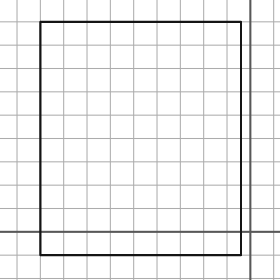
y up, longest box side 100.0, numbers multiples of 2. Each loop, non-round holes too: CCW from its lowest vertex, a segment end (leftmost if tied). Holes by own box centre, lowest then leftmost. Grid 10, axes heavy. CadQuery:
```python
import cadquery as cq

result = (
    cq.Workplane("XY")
    .moveTo(-90.0, -10.0)
    .lineTo(-4.0, -10.0)
    .lineTo(-4.0, 90.0)
    .lineTo(-90.0, 90.0)
    .close()
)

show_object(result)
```